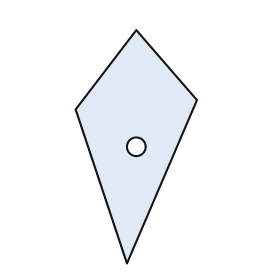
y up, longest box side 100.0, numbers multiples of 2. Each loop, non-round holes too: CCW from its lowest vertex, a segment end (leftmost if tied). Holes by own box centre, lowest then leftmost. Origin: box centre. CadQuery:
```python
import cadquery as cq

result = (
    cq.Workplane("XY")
    .moveTo(-4.0, -50.0)
    .lineTo(26.0, 20.0)
    .lineTo(0.0, 50.0)
    .lineTo(-26.0, 16.0)
    .close()
    .moveTo(0.0, 0.0)
    .circle(4.0)
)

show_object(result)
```